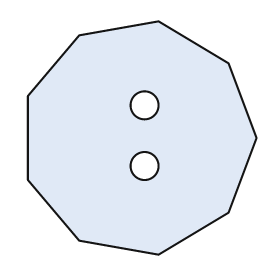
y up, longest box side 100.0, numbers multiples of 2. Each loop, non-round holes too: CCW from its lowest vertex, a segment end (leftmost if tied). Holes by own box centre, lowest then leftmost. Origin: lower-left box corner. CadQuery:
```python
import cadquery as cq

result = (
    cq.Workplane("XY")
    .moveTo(56.0, 0.0)
    .lineTo(86.0, 18.0)
    .lineTo(98.0, 50.0)
    .lineTo(86.0, 82.0)
    .lineTo(56.0, 100.0)
    .lineTo(22.0, 94.0)
    .lineTo(0.0, 68.0)
    .lineTo(0.0, 32.0)
    .lineTo(22.0, 6.0)
    .close()
    .moveTo(50.0, 38.0)
    .circle(6.0)
    .moveTo(50.0, 64.0)
    .circle(6.0)
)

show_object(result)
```